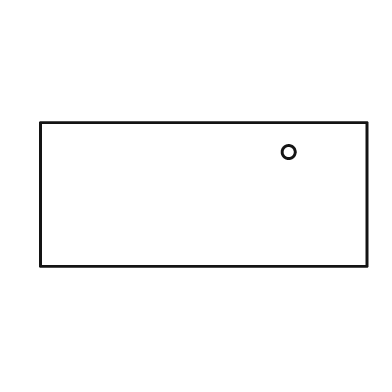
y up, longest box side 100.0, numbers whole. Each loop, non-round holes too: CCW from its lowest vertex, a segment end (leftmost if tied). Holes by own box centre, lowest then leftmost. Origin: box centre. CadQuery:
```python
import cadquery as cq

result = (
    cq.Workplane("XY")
    .moveTo(-50.0, -22.0)
    .lineTo(50.0, -22.0)
    .lineTo(50.0, 22.0)
    .lineTo(-50.0, 22.0)
    .close()
    .moveTo(26.0, 13.0)
    .circle(2.0)
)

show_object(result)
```